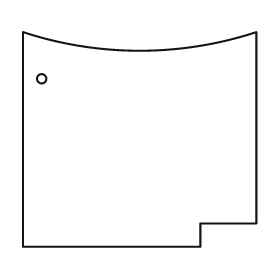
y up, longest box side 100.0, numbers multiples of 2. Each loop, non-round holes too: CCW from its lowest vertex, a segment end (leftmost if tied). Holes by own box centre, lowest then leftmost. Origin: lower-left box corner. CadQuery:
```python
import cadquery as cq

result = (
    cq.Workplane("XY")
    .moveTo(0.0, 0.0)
    .lineTo(76.0, 0.0)
    .lineTo(76.0, 10.0)
    .lineTo(100.0, 10.0)
    .lineTo(100.0, 92.0)
    .threePointArc((50.0, 84.0), (0.0, 92.0))
    .close()
    .moveTo(8.0, 72.0)
    .circle(2.0)
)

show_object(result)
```